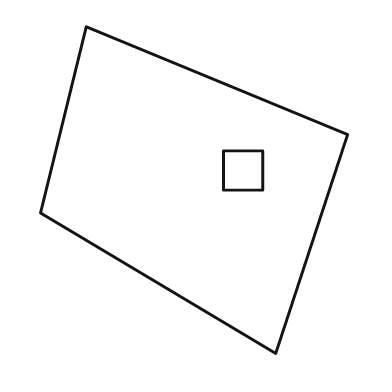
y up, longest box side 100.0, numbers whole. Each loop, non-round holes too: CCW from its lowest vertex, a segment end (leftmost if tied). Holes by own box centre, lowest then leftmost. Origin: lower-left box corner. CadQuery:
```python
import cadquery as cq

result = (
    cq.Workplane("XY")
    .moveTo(72.0, 0.0)
    .lineTo(94.0, 67.0)
    .lineTo(14.0, 100.0)
    .lineTo(0.0, 43.0)
    .close()
    .moveTo(56.0, 50.0)
    .lineTo(68.0, 50.0)
    .lineTo(68.0, 62.0)
    .lineTo(56.0, 62.0)
    .close()
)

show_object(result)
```